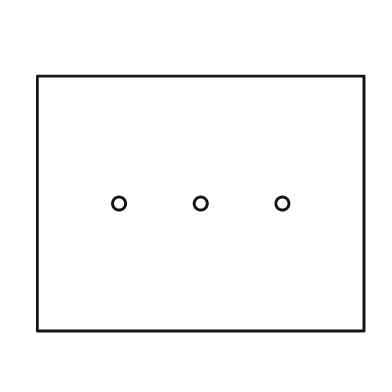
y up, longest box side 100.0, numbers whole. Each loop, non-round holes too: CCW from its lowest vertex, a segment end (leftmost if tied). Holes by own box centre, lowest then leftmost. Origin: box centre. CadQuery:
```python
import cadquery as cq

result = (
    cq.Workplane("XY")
    .moveTo(-50.0, -39.0)
    .lineTo(50.0, -39.0)
    .lineTo(50.0, 39.0)
    .lineTo(-50.0, 39.0)
    .close()
    .moveTo(-25.0, 0.0)
    .circle(2.0)
    .moveTo(0.0, 0.0)
    .circle(2.0)
    .moveTo(25.0, 0.0)
    .circle(2.0)
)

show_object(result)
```